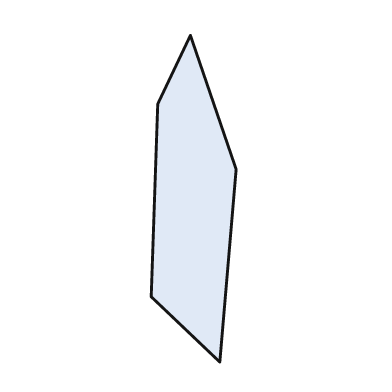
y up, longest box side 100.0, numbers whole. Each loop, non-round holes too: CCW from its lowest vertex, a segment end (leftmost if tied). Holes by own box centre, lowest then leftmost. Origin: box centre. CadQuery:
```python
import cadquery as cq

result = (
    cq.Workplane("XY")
    .moveTo(8.0, -50.0)
    .lineTo(13.0, 9.0)
    .lineTo(-1.0, 50.0)
    .lineTo(-11.0, 29.0)
    .lineTo(-13.0, -30.0)
    .close()
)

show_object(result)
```